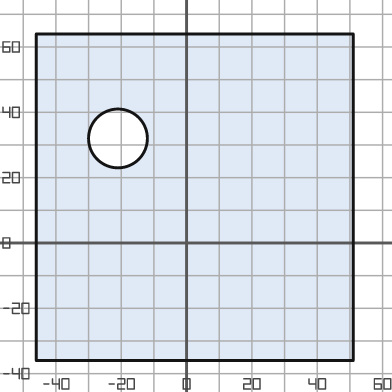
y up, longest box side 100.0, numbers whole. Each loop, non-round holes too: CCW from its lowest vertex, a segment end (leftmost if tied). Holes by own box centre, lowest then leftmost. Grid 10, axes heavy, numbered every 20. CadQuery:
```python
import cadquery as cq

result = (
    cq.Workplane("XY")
    .moveTo(-46.0, -36.0)
    .lineTo(51.0, -36.0)
    .lineTo(51.0, 64.0)
    .lineTo(-46.0, 64.0)
    .close()
    .moveTo(-21.0, 32.0)
    .circle(9.0)
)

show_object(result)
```